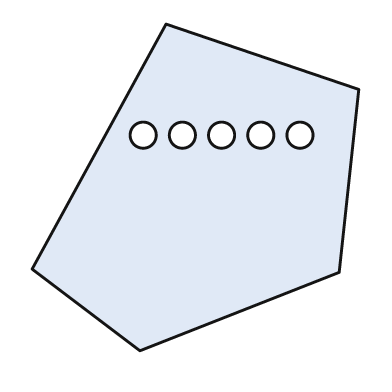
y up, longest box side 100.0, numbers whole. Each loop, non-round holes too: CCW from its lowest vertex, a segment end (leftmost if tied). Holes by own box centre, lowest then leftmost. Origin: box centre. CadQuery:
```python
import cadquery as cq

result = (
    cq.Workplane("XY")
    .moveTo(-17.0, -50.0)
    .lineTo(44.0, -26.0)
    .lineTo(50.0, 30.0)
    .lineTo(-9.0, 50.0)
    .lineTo(-50.0, -25.0)
    .close()
    .moveTo(-16.0, 16.0)
    .circle(4.0)
    .moveTo(-4.0, 16.0)
    .circle(4.0)
    .moveTo(8.0, 16.0)
    .circle(4.0)
    .moveTo(20.0, 16.0)
    .circle(4.0)
    .moveTo(32.0, 16.0)
    .circle(4.0)
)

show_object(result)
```